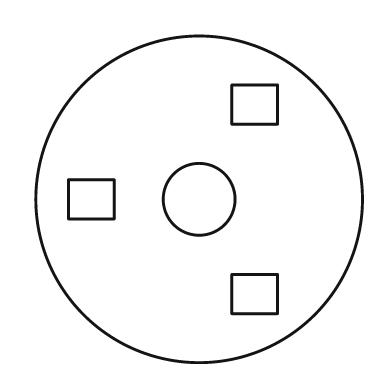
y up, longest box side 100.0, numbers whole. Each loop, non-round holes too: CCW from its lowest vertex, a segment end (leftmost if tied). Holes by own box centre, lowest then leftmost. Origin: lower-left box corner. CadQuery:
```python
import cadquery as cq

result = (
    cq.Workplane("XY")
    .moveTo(50.0, 50.0)
    .circle(50.0)
    .moveTo(60.0, 15.0)
    .lineTo(74.0, 15.0)
    .lineTo(74.0, 27.0)
    .lineTo(60.0, 27.0)
    .close()
    .moveTo(10.0, 44.0)
    .lineTo(24.0, 44.0)
    .lineTo(24.0, 56.0)
    .lineTo(10.0, 56.0)
    .close()
    .moveTo(50.0, 50.0)
    .circle(11.0)
    .moveTo(60.0, 73.0)
    .lineTo(74.0, 73.0)
    .lineTo(74.0, 85.0)
    .lineTo(60.0, 85.0)
    .close()
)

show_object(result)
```